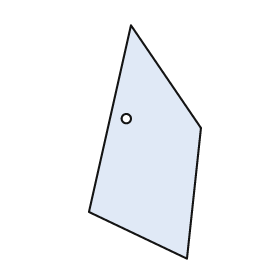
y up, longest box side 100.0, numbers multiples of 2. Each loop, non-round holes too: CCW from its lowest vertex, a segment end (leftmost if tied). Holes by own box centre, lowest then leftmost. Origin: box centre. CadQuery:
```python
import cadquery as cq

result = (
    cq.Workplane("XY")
    .moveTo(18.0, -50.0)
    .lineTo(24.0, 6.0)
    .lineTo(-6.0, 50.0)
    .lineTo(-24.0, -30.0)
    .close()
    .moveTo(-8.0, 10.0)
    .circle(2.0)
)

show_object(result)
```